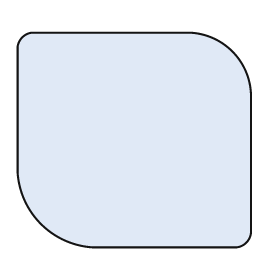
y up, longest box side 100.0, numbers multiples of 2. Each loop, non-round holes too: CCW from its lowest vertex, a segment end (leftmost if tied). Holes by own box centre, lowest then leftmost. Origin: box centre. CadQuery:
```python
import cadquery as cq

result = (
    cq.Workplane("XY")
    .moveTo(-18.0, -46.0)
    .lineTo(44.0, -46.0)
    .threePointArc((48.0, -44.0), (50.0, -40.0))
    .lineTo(50.0, 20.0)
    .threePointArc((42.0, 38.0), (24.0, 46.0))
    .lineTo(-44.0, 46.0)
    .threePointArc((-48.0, 44.0), (-50.0, 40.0))
    .lineTo(-50.0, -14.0)
    .threePointArc((-40.0, -36.0), (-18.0, -46.0))
    .close()
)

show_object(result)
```